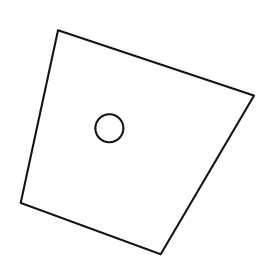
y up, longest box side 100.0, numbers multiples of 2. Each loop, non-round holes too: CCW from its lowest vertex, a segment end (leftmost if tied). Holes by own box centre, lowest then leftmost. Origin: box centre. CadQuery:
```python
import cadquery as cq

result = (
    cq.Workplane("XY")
    .moveTo(10.0, -48.0)
    .lineTo(50.0, 20.0)
    .lineTo(-34.0, 48.0)
    .lineTo(-50.0, -26.0)
    .close()
    .moveTo(-12.0, 6.0)
    .circle(6.0)
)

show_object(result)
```